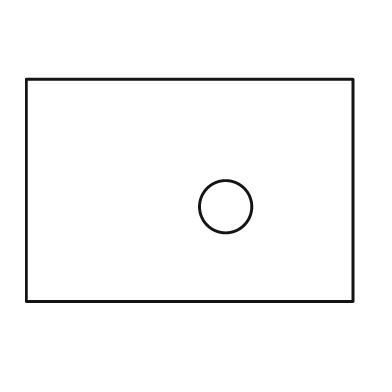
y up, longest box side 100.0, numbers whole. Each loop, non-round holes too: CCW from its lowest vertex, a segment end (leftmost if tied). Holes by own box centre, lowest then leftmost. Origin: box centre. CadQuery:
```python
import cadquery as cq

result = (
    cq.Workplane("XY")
    .moveTo(-50.0, -34.0)
    .lineTo(50.0, -34.0)
    .lineTo(50.0, 34.0)
    .lineTo(-50.0, 34.0)
    .close()
    .moveTo(11.0, -5.0)
    .circle(8.0)
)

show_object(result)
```